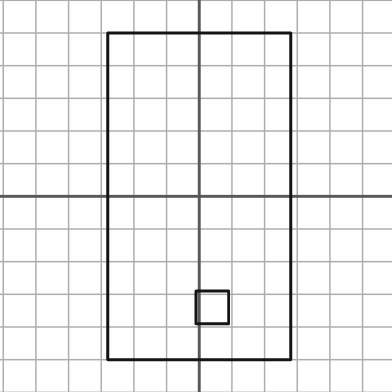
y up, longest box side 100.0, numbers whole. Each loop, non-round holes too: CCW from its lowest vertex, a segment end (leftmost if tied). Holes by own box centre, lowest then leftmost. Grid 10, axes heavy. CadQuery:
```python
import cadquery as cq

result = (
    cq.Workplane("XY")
    .moveTo(-28.0, -50.0)
    .lineTo(28.0, -50.0)
    .lineTo(28.0, 50.0)
    .lineTo(-28.0, 50.0)
    .close()
    .moveTo(-1.0, -39.0)
    .lineTo(9.0, -39.0)
    .lineTo(9.0, -29.0)
    .lineTo(-1.0, -29.0)
    .close()
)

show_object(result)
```